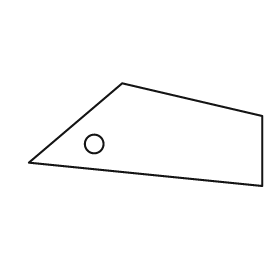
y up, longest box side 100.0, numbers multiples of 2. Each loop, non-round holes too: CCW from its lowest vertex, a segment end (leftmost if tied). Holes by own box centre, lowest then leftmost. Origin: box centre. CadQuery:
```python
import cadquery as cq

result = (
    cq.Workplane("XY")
    .moveTo(50.0, -22.0)
    .lineTo(50.0, 8.0)
    .lineTo(-10.0, 22.0)
    .lineTo(-50.0, -12.0)
    .close()
    .moveTo(-22.0, -4.0)
    .circle(4.0)
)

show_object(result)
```